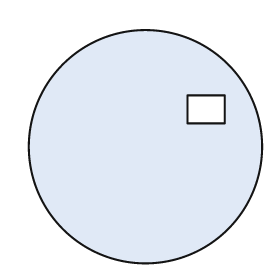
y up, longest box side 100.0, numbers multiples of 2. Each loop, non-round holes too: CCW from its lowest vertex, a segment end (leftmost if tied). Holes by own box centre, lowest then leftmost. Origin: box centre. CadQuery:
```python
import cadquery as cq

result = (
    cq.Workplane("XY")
    .moveTo(0.0, 0.0)
    .circle(50.0)
    .moveTo(18.0, 10.0)
    .lineTo(34.0, 10.0)
    .lineTo(34.0, 22.0)
    .lineTo(18.0, 22.0)
    .close()
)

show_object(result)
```